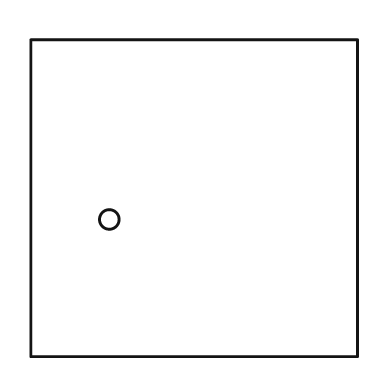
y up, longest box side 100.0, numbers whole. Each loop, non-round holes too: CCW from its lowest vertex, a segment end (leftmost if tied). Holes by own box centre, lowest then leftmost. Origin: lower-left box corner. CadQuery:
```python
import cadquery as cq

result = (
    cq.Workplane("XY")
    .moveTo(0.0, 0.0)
    .lineTo(100.0, 0.0)
    .lineTo(100.0, 97.0)
    .lineTo(0.0, 97.0)
    .close()
    .moveTo(24.0, 42.0)
    .circle(3.0)
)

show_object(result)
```